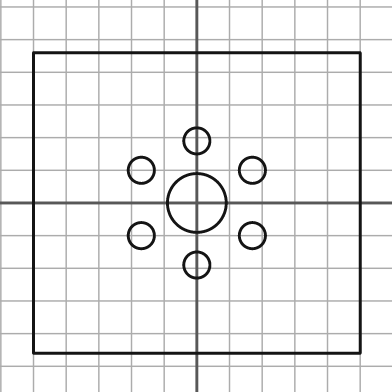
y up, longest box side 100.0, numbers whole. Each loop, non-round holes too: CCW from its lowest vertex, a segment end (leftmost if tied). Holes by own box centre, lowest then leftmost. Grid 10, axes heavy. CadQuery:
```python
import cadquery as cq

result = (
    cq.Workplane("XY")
    .moveTo(-50.0, -46.0)
    .lineTo(50.0, -46.0)
    .lineTo(50.0, 46.0)
    .lineTo(-50.0, 46.0)
    .close()
    .moveTo(0.0, -19.0)
    .circle(4.0)
    .moveTo(-17.0, -10.0)
    .circle(4.0)
    .moveTo(17.0, -10.0)
    .circle(4.0)
    .moveTo(0.0, 0.0)
    .circle(9.0)
    .moveTo(-17.0, 10.0)
    .circle(4.0)
    .moveTo(17.0, 10.0)
    .circle(4.0)
    .moveTo(0.0, 19.0)
    .circle(4.0)
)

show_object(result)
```